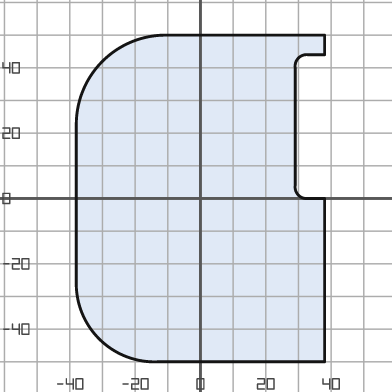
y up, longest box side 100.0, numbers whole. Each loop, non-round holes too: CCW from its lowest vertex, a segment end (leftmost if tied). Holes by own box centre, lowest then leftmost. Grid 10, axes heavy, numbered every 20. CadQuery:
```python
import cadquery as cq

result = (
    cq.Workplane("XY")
    .moveTo(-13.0, -50.0)
    .lineTo(38.0, -50.0)
    .lineTo(38.0, 0.0)
    .lineTo(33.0, 0.0)
    .threePointArc((30.0, 1.0), (29.0, 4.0))
    .lineTo(29.0, 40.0)
    .threePointArc((30.0, 43.0), (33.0, 44.0))
    .lineTo(38.0, 44.0)
    .lineTo(38.0, 50.0)
    .lineTo(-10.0, 50.0)
    .threePointArc((-30.0, 42.0), (-38.0, 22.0))
    .lineTo(-38.0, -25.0)
    .threePointArc((-31.0, -43.0), (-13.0, -50.0))
    .close()
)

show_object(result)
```